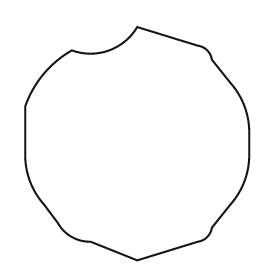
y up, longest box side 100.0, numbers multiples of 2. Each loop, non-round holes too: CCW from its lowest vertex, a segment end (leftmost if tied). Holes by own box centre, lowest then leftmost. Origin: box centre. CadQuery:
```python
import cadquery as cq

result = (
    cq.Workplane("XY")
    .moveTo(0.0, -50.0)
    .lineTo(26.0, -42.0)
    .threePointArc((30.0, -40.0), (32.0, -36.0))
    .lineTo(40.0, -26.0)
    .threePointArc((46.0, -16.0), (48.0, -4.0))
    .lineTo(48.0, 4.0)
    .threePointArc((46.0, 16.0), (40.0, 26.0))
    .lineTo(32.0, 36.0)
    .threePointArc((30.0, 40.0), (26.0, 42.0))
    .lineTo(0.0, 50.0)
    .threePointArc((-12.0, 40.0), (-28.0, 40.0))
    .threePointArc((-40.0, 30.0), (-48.0, 16.0))
    .lineTo(-48.0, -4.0)
    .threePointArc((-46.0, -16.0), (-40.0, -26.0))
    .lineTo(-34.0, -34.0)
    .threePointArc((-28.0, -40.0), (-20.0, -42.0))
    .close()
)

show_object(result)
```